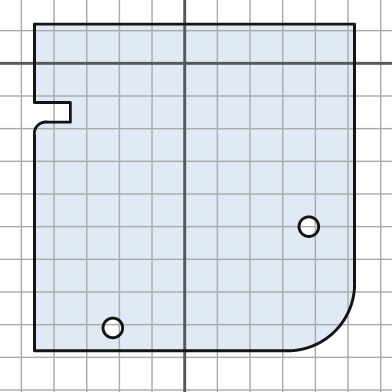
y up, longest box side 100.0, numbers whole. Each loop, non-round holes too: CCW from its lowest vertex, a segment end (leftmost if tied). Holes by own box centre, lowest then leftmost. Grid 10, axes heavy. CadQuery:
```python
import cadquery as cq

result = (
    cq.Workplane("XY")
    .moveTo(-46.0, -88.0)
    .lineTo(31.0, -88.0)
    .threePointArc((46.0, -82.0), (52.0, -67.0))
    .lineTo(52.0, 12.0)
    .lineTo(-46.0, 12.0)
    .lineTo(-46.0, -12.0)
    .lineTo(-35.0, -12.0)
    .lineTo(-35.0, -18.0)
    .lineTo(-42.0, -18.0)
    .threePointArc((-45.0, -19.0), (-46.0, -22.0))
    .close()
    .moveTo(-22.0, -81.0)
    .circle(3.0)
    .moveTo(38.0, -50.0)
    .circle(3.0)
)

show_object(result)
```